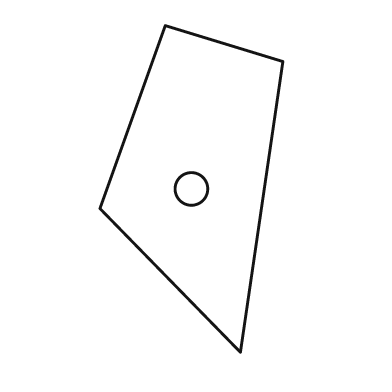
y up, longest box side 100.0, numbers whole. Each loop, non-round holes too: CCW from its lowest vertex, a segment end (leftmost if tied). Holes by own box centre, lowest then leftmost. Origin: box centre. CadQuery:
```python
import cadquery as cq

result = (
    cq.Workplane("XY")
    .moveTo(15.0, -50.0)
    .lineTo(28.0, 39.0)
    .lineTo(-8.0, 50.0)
    .lineTo(-28.0, -6.0)
    .close()
    .moveTo(0.0, 0.0)
    .circle(5.0)
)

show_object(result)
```